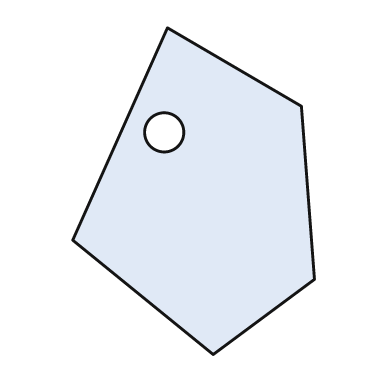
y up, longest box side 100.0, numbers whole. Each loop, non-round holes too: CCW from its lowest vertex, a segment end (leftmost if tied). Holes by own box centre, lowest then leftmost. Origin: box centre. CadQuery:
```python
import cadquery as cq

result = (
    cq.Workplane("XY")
    .moveTo(6.0, -50.0)
    .lineTo(37.0, -27.0)
    .lineTo(33.0, 26.0)
    .lineTo(-8.0, 50.0)
    .lineTo(-37.0, -15.0)
    .close()
    .moveTo(-9.0, 18.0)
    .circle(6.0)
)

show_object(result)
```